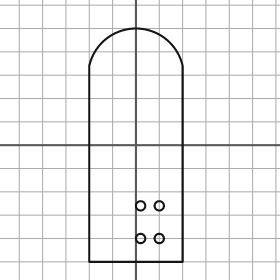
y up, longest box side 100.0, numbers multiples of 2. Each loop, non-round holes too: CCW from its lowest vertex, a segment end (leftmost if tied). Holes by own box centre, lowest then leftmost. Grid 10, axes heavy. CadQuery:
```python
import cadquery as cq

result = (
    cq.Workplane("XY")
    .moveTo(-20.0, -50.0)
    .lineTo(20.0, -50.0)
    .lineTo(20.0, 34.0)
    .threePointArc((0.0, 50.0), (-20.0, 34.0))
    .close()
    .moveTo(2.0, -40.0)
    .circle(2.0)
    .moveTo(10.0, -40.0)
    .circle(2.0)
    .moveTo(2.0, -26.0)
    .circle(2.0)
    .moveTo(10.0, -26.0)
    .circle(2.0)
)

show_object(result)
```